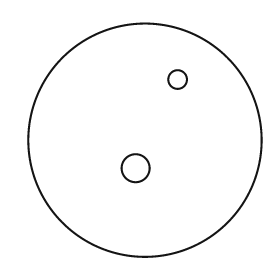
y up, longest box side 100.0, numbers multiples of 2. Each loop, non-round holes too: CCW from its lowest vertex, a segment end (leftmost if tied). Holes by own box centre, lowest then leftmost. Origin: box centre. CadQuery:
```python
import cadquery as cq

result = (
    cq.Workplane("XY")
    .moveTo(0.0, 0.0)
    .circle(50.0)
    .moveTo(-4.0, -12.0)
    .circle(6.0)
    .moveTo(14.0, 26.0)
    .circle(4.0)
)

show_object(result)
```